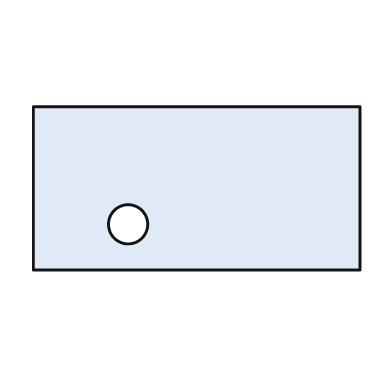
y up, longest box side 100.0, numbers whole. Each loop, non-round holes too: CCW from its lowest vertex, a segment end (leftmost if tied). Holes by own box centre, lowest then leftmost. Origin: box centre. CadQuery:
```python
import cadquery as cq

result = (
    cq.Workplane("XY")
    .moveTo(-50.0, -25.0)
    .lineTo(50.0, -25.0)
    .lineTo(50.0, 25.0)
    .lineTo(-50.0, 25.0)
    .close()
    .moveTo(-21.0, -11.0)
    .circle(6.0)
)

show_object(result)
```